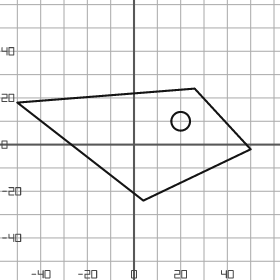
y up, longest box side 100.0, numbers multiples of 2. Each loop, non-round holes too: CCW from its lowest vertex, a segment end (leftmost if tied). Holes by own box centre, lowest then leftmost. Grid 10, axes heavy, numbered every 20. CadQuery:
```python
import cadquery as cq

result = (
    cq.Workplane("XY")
    .moveTo(4.0, -24.0)
    .lineTo(50.0, -2.0)
    .lineTo(26.0, 24.0)
    .lineTo(-50.0, 18.0)
    .close()
    .moveTo(20.0, 10.0)
    .circle(4.0)
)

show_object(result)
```